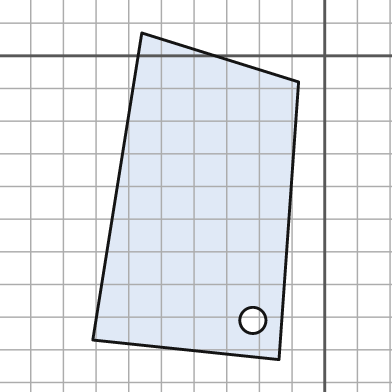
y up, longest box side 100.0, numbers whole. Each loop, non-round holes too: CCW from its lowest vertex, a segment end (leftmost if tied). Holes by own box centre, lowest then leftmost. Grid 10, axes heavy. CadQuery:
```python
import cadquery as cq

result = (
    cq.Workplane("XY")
    .moveTo(-14.0, -93.0)
    .lineTo(-8.0, -8.0)
    .lineTo(-56.0, 7.0)
    .lineTo(-71.0, -87.0)
    .close()
    .moveTo(-22.0, -81.0)
    .circle(4.0)
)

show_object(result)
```